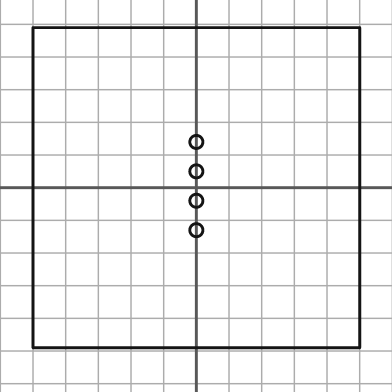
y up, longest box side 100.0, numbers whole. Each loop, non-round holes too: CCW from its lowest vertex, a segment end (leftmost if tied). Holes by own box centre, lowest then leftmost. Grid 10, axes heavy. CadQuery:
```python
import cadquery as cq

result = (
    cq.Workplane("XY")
    .moveTo(-50.0, -49.0)
    .lineTo(50.0, -49.0)
    .lineTo(50.0, 49.0)
    .lineTo(-50.0, 49.0)
    .close()
    .moveTo(0.0, -13.0)
    .circle(2.0)
    .moveTo(0.0, -4.0)
    .circle(2.0)
    .moveTo(0.0, 5.0)
    .circle(2.0)
    .moveTo(0.0, 14.0)
    .circle(2.0)
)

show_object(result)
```